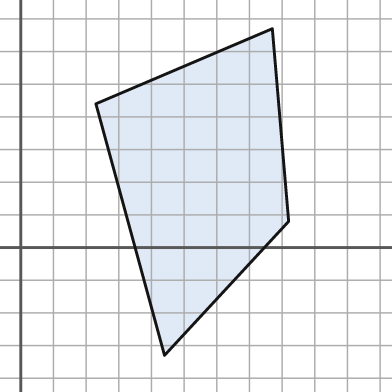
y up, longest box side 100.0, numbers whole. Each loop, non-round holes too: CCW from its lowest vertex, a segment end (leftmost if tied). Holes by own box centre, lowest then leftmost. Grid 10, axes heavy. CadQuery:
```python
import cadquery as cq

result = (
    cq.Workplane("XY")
    .moveTo(44.0, -33.0)
    .lineTo(82.0, 8.0)
    .lineTo(77.0, 67.0)
    .lineTo(23.0, 44.0)
    .close()
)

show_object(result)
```